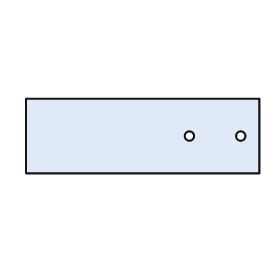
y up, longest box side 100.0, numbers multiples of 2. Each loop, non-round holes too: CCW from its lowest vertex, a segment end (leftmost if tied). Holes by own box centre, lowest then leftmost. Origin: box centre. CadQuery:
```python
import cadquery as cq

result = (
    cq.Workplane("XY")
    .moveTo(-50.0, -16.0)
    .lineTo(50.0, -16.0)
    .lineTo(50.0, 16.0)
    .lineTo(-50.0, 16.0)
    .close()
    .moveTo(20.0, 0.0)
    .circle(2.0)
    .moveTo(42.0, 0.0)
    .circle(2.0)
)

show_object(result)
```